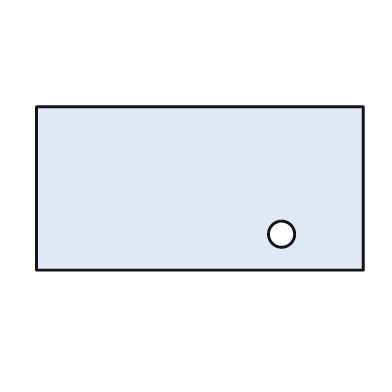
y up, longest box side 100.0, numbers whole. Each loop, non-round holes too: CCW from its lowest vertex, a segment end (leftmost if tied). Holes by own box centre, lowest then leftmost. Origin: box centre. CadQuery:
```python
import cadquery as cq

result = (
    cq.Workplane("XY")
    .moveTo(-50.0, -25.0)
    .lineTo(50.0, -25.0)
    .lineTo(50.0, 25.0)
    .lineTo(-50.0, 25.0)
    .close()
    .moveTo(25.0, -14.0)
    .circle(4.0)
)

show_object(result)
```